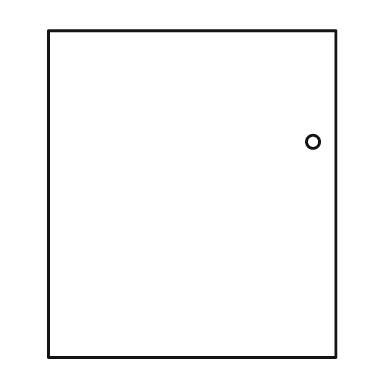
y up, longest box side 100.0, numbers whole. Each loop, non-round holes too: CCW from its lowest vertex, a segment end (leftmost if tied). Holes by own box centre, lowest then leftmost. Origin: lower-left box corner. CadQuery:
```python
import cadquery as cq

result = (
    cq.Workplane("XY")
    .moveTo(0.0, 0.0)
    .lineTo(88.0, 0.0)
    .lineTo(88.0, 100.0)
    .lineTo(0.0, 100.0)
    .close()
    .moveTo(81.0, 66.0)
    .circle(2.0)
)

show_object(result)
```